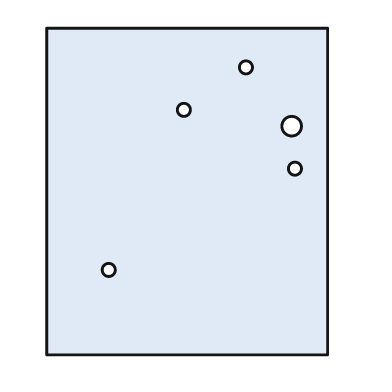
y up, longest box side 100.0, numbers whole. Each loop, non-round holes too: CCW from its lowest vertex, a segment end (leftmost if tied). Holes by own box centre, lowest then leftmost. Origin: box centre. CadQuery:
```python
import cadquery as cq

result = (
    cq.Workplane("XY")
    .moveTo(-43.0, -50.0)
    .lineTo(43.0, -50.0)
    .lineTo(43.0, 50.0)
    .lineTo(-43.0, 50.0)
    .close()
    .moveTo(-24.0, -24.0)
    .circle(2.0)
    .moveTo(33.0, 7.0)
    .circle(2.0)
    .moveTo(32.0, 20.0)
    .circle(3.0)
    .moveTo(-1.0, 25.0)
    .circle(2.0)
    .moveTo(18.0, 38.0)
    .circle(2.0)
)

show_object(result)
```